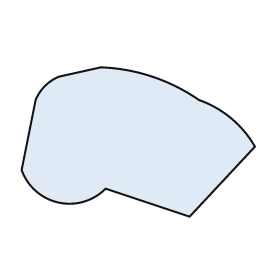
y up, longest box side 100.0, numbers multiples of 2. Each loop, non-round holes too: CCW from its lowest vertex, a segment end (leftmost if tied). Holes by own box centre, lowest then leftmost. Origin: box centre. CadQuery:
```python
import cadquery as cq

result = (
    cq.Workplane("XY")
    .moveTo(22.0, -32.0)
    .lineTo(50.0, -2.0)
    .threePointArc((40.0, 10.0), (26.0, 18.0))
    .threePointArc((6.0, 28.0), (-16.0, 32.0))
    .lineTo(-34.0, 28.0)
    .threePointArc((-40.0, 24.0), (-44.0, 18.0))
    .lineTo(-50.0, -12.0)
    .threePointArc((-34.0, -26.0), (-14.0, -20.0))
    .close()
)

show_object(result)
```